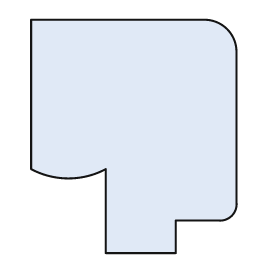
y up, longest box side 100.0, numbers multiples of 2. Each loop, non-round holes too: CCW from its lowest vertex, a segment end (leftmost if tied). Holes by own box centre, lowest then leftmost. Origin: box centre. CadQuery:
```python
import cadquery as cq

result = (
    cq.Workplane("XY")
    .moveTo(-12.0, -50.0)
    .lineTo(18.0, -50.0)
    .lineTo(18.0, -36.0)
    .lineTo(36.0, -36.0)
    .threePointArc((42.0, -34.0), (44.0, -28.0))
    .lineTo(44.0, 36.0)
    .threePointArc((40.0, 46.0), (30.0, 50.0))
    .lineTo(-44.0, 50.0)
    .lineTo(-44.0, -14.0)
    .threePointArc((-28.0, -18.0), (-12.0, -14.0))
    .close()
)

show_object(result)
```